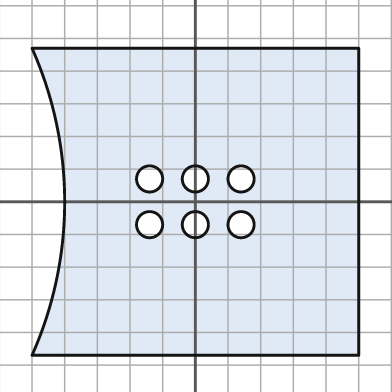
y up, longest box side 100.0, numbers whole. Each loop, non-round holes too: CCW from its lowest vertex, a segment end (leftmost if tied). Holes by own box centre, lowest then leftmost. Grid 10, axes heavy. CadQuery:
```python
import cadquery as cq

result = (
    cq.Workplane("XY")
    .moveTo(-50.0, -47.0)
    .lineTo(50.0, -47.0)
    .lineTo(50.0, 47.0)
    .lineTo(-50.0, 47.0)
    .threePointArc((-40.0, 0.0), (-50.0, -47.0))
    .close()
    .moveTo(-14.0, -7.0)
    .circle(4.0)
    .moveTo(0.0, -7.0)
    .circle(4.0)
    .moveTo(14.0, -7.0)
    .circle(4.0)
    .moveTo(-14.0, 7.0)
    .circle(4.0)
    .moveTo(0.0, 7.0)
    .circle(4.0)
    .moveTo(14.0, 7.0)
    .circle(4.0)
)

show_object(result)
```